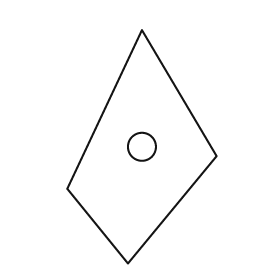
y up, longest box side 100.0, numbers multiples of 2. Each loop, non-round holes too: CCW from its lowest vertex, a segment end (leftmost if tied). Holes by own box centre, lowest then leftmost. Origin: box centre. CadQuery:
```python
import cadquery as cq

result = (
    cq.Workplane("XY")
    .moveTo(-6.0, -50.0)
    .lineTo(32.0, -4.0)
    .lineTo(0.0, 50.0)
    .lineTo(-32.0, -18.0)
    .close()
    .moveTo(0.0, 0.0)
    .circle(6.0)
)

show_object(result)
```